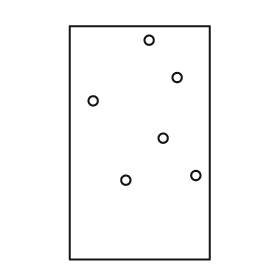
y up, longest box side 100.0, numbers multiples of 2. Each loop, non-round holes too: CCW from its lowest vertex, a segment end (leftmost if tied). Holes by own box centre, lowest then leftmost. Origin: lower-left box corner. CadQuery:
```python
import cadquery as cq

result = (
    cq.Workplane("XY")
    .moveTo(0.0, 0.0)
    .lineTo(60.0, 0.0)
    .lineTo(60.0, 100.0)
    .lineTo(0.0, 100.0)
    .close()
    .moveTo(24.0, 34.0)
    .circle(2.0)
    .moveTo(54.0, 36.0)
    .circle(2.0)
    .moveTo(40.0, 52.0)
    .circle(2.0)
    .moveTo(10.0, 68.0)
    .circle(2.0)
    .moveTo(46.0, 78.0)
    .circle(2.0)
    .moveTo(34.0, 94.0)
    .circle(2.0)
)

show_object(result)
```